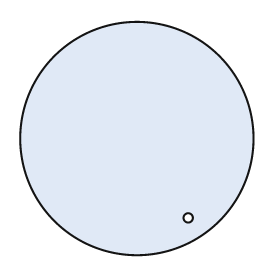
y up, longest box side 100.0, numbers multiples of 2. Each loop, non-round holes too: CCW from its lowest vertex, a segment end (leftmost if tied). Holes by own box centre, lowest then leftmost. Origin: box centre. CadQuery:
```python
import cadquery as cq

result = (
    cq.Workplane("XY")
    .moveTo(0.0, 0.0)
    .circle(50.0)
    .moveTo(22.0, -34.0)
    .circle(2.0)
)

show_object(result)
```